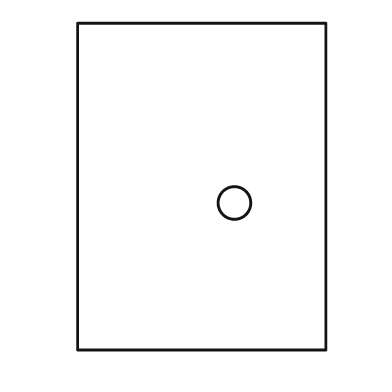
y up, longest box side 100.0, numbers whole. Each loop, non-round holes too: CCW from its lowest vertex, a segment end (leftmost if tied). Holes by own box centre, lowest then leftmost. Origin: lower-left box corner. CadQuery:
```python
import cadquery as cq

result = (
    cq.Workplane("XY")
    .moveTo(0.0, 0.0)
    .lineTo(76.0, 0.0)
    .lineTo(76.0, 100.0)
    .lineTo(0.0, 100.0)
    .close()
    .moveTo(48.0, 45.0)
    .circle(5.0)
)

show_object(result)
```